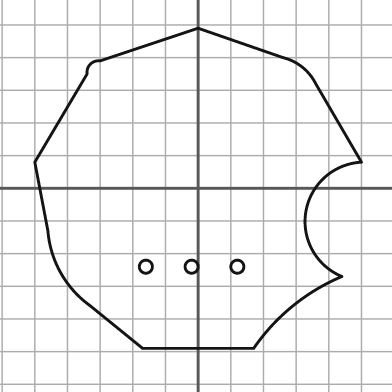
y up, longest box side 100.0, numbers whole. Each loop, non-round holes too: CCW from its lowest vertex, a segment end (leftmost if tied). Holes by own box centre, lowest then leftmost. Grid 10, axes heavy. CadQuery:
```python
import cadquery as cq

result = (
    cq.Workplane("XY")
    .moveTo(-17.0, -49.0)
    .lineTo(17.0, -49.0)
    .threePointArc((29.0, -36.0), (44.0, -27.0))
    .threePointArc((33.0, -7.0), (50.0, 8.0))
    .lineTo(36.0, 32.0)
    .threePointArc((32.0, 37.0), (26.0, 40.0))
    .lineTo(0.0, 49.0)
    .lineTo(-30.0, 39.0)
    .threePointArc((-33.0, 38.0), (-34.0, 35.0))
    .lineTo(-50.0, 8.0)
    .lineTo(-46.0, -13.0)
    .threePointArc((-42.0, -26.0), (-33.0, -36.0))
    .close()
    .moveTo(-16.0, -24.0)
    .circle(2.0)
    .moveTo(-2.0, -24.0)
    .circle(2.0)
    .moveTo(12.0, -24.0)
    .circle(2.0)
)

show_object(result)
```